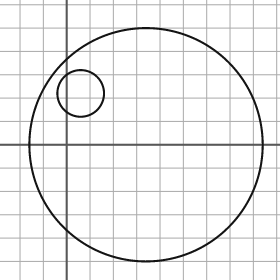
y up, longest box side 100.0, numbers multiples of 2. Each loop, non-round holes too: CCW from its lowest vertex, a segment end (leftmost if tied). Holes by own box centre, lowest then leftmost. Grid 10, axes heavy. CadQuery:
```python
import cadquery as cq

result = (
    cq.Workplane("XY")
    .moveTo(34.0, 0.0)
    .circle(50.0)
    .moveTo(6.0, 22.0)
    .circle(10.0)
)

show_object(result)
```